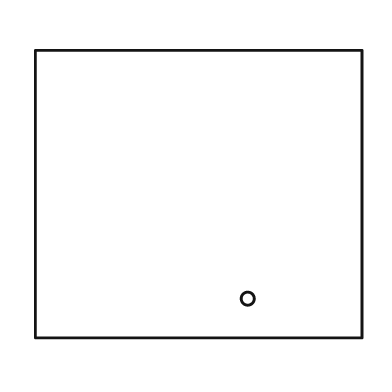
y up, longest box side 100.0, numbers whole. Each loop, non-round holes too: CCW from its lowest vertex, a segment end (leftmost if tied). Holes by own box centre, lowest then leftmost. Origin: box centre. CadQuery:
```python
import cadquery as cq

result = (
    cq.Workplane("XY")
    .moveTo(-50.0, -44.0)
    .lineTo(50.0, -44.0)
    .lineTo(50.0, 44.0)
    .lineTo(-50.0, 44.0)
    .close()
    .moveTo(15.0, -32.0)
    .circle(2.0)
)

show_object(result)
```